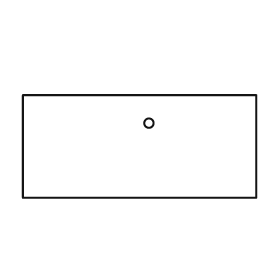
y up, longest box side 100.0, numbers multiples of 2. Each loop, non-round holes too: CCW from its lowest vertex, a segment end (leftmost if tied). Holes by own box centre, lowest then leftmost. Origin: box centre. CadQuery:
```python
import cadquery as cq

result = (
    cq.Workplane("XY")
    .moveTo(-50.0, -22.0)
    .lineTo(50.0, -22.0)
    .lineTo(50.0, 22.0)
    .lineTo(-50.0, 22.0)
    .close()
    .moveTo(4.0, 10.0)
    .circle(2.0)
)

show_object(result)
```